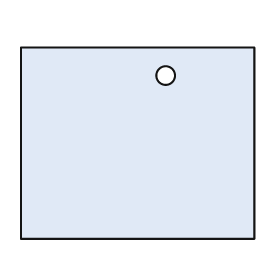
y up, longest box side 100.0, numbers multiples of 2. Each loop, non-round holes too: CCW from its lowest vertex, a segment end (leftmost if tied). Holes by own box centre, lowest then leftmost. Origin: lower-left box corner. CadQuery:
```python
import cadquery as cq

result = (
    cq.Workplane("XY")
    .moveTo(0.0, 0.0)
    .lineTo(100.0, 0.0)
    .lineTo(100.0, 82.0)
    .lineTo(0.0, 82.0)
    .close()
    .moveTo(62.0, 70.0)
    .circle(4.0)
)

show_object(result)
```